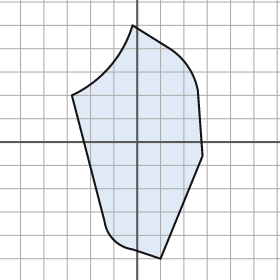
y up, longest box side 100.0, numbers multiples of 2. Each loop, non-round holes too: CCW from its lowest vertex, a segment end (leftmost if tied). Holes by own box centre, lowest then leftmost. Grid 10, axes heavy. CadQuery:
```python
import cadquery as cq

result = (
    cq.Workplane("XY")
    .moveTo(10.0, -50.0)
    .lineTo(28.0, -6.0)
    .lineTo(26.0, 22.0)
    .threePointArc((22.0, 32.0), (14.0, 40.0))
    .lineTo(-2.0, 50.0)
    .threePointArc((-12.0, 32.0), (-28.0, 20.0))
    .lineTo(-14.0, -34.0)
    .threePointArc((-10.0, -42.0), (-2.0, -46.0))
    .close()
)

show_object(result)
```